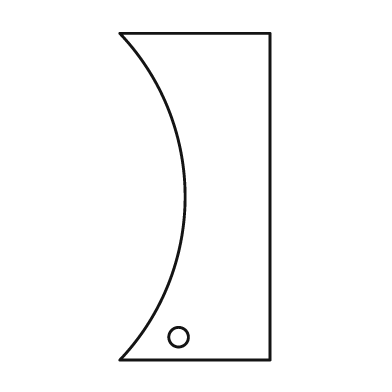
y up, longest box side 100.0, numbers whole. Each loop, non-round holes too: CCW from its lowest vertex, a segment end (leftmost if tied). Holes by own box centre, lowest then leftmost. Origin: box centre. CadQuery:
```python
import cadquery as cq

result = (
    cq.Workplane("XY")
    .moveTo(-23.0, -50.0)
    .lineTo(23.0, -50.0)
    .lineTo(23.0, 50.0)
    .lineTo(-23.0, 50.0)
    .threePointArc((-3.0, 0.0), (-23.0, -50.0))
    .close()
    .moveTo(-5.0, -43.0)
    .circle(3.0)
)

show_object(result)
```